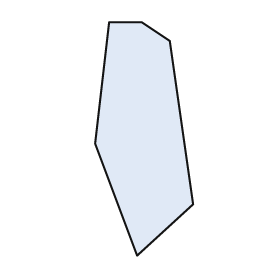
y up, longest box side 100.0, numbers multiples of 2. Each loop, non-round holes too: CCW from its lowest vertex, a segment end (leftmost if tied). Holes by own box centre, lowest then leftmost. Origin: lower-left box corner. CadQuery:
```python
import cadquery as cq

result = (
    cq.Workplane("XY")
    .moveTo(18.0, 0.0)
    .lineTo(42.0, 22.0)
    .lineTo(32.0, 92.0)
    .lineTo(20.0, 100.0)
    .lineTo(6.0, 100.0)
    .lineTo(0.0, 48.0)
    .close()
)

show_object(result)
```